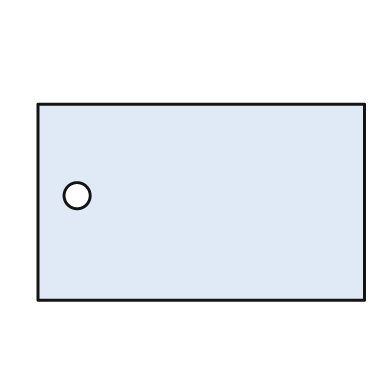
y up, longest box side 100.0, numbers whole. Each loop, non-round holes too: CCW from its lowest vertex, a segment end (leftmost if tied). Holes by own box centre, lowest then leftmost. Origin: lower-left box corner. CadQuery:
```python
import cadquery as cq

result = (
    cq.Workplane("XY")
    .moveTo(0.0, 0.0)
    .lineTo(100.0, 0.0)
    .lineTo(100.0, 60.0)
    .lineTo(0.0, 60.0)
    .close()
    .moveTo(12.0, 32.0)
    .circle(4.0)
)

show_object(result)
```